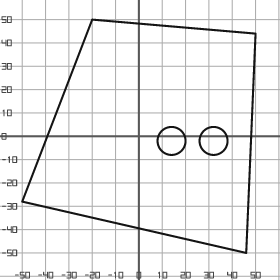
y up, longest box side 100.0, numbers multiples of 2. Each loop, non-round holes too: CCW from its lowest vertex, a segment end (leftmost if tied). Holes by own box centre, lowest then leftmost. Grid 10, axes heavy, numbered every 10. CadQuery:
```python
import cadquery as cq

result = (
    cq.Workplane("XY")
    .moveTo(46.0, -50.0)
    .lineTo(50.0, 44.0)
    .lineTo(-20.0, 50.0)
    .lineTo(-50.0, -28.0)
    .close()
    .moveTo(14.0, -2.0)
    .circle(6.0)
    .moveTo(32.0, -2.0)
    .circle(6.0)
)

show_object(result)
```